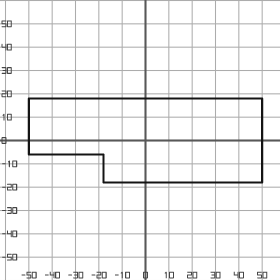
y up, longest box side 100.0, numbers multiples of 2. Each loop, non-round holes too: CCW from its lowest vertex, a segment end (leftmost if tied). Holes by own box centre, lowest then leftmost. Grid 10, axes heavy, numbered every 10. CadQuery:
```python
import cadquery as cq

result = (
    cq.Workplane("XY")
    .moveTo(-18.0, -18.0)
    .lineTo(50.0, -18.0)
    .lineTo(50.0, 18.0)
    .lineTo(-50.0, 18.0)
    .lineTo(-50.0, -6.0)
    .lineTo(-18.0, -6.0)
    .close()
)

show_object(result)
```